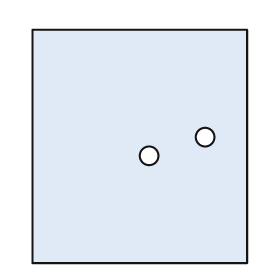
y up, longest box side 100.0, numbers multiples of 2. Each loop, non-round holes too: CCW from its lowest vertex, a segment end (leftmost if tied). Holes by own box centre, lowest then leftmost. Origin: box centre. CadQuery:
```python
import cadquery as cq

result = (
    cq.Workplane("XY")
    .moveTo(-46.0, -50.0)
    .lineTo(46.0, -50.0)
    .lineTo(46.0, 50.0)
    .lineTo(-46.0, 50.0)
    .close()
    .moveTo(4.0, -4.0)
    .circle(4.0)
    .moveTo(28.0, 4.0)
    .circle(4.0)
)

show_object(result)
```